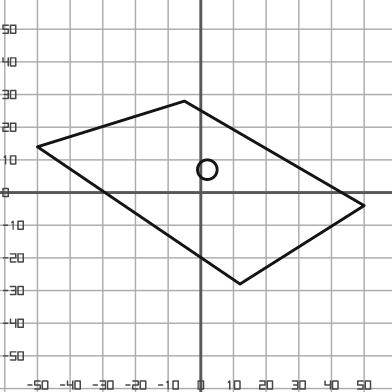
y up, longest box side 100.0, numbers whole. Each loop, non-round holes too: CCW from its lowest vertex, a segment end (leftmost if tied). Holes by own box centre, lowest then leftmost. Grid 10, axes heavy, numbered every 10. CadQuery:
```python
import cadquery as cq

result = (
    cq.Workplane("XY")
    .moveTo(12.0, -28.0)
    .lineTo(50.0, -4.0)
    .lineTo(-5.0, 28.0)
    .lineTo(-50.0, 14.0)
    .close()
    .moveTo(2.0, 7.0)
    .circle(3.0)
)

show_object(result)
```